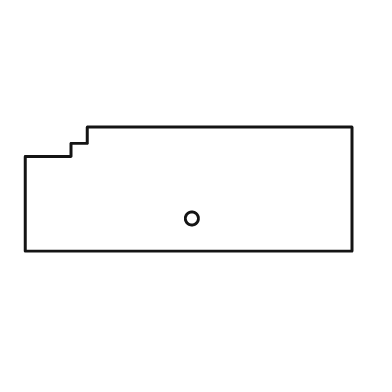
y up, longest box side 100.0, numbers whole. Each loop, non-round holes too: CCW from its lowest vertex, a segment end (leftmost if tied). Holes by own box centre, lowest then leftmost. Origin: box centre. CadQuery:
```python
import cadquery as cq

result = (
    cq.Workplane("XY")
    .moveTo(-50.0, -19.0)
    .lineTo(50.0, -19.0)
    .lineTo(50.0, 19.0)
    .lineTo(-31.0, 19.0)
    .lineTo(-31.0, 14.0)
    .lineTo(-36.0, 14.0)
    .lineTo(-36.0, 10.0)
    .lineTo(-50.0, 10.0)
    .close()
    .moveTo(1.0, -9.0)
    .circle(2.0)
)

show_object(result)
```